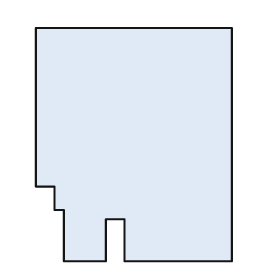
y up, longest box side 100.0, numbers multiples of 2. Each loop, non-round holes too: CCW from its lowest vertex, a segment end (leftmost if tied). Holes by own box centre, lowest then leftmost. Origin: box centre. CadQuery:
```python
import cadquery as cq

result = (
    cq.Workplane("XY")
    .moveTo(-30.0, -50.0)
    .lineTo(-12.0, -50.0)
    .lineTo(-12.0, -32.0)
    .lineTo(-4.0, -32.0)
    .lineTo(-4.0, -50.0)
    .lineTo(42.0, -50.0)
    .lineTo(42.0, 50.0)
    .lineTo(-42.0, 50.0)
    .lineTo(-42.0, -18.0)
    .lineTo(-34.0, -18.0)
    .lineTo(-34.0, -28.0)
    .lineTo(-30.0, -28.0)
    .close()
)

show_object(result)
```